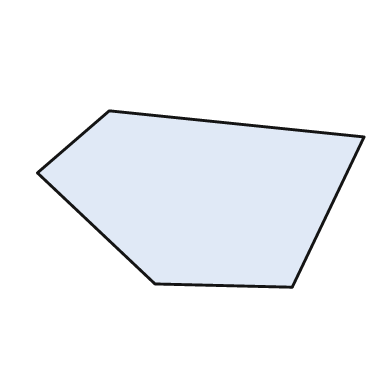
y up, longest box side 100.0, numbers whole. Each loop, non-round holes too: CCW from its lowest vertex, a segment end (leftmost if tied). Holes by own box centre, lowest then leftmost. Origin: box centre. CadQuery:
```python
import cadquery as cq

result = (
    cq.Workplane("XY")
    .moveTo(28.0, -27.0)
    .lineTo(50.0, 19.0)
    .lineTo(-28.0, 27.0)
    .lineTo(-50.0, 8.0)
    .lineTo(-14.0, -26.0)
    .close()
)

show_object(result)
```